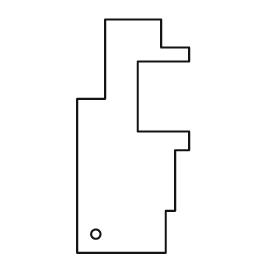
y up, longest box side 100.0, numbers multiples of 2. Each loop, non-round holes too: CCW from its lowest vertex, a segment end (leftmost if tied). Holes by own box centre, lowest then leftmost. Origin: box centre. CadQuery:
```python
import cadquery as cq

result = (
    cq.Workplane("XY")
    .moveTo(-24.0, -50.0)
    .lineTo(14.0, -50.0)
    .lineTo(14.0, -32.0)
    .lineTo(18.0, -32.0)
    .lineTo(18.0, -6.0)
    .lineTo(24.0, -6.0)
    .lineTo(24.0, 2.0)
    .lineTo(2.0, 2.0)
    .lineTo(2.0, 32.0)
    .lineTo(24.0, 32.0)
    .lineTo(24.0, 38.0)
    .lineTo(12.0, 38.0)
    .lineTo(12.0, 50.0)
    .lineTo(-12.0, 50.0)
    .lineTo(-12.0, 16.0)
    .lineTo(-24.0, 16.0)
    .close()
    .moveTo(-16.0, -42.0)
    .circle(2.0)
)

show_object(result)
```